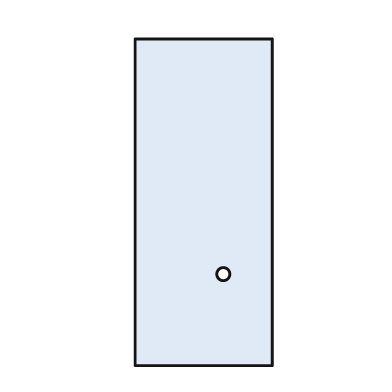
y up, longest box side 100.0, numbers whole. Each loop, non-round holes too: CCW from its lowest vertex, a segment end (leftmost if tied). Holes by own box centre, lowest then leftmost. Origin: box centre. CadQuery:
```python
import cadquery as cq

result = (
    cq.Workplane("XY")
    .moveTo(-21.0, -50.0)
    .lineTo(21.0, -50.0)
    .lineTo(21.0, 50.0)
    .lineTo(-21.0, 50.0)
    .close()
    .moveTo(6.0, -22.0)
    .circle(2.0)
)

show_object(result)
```